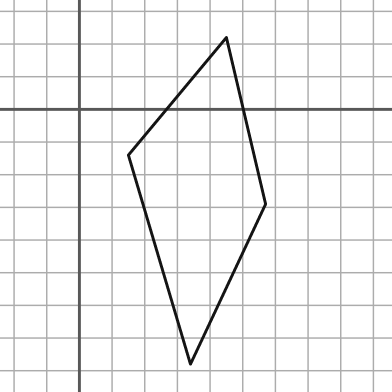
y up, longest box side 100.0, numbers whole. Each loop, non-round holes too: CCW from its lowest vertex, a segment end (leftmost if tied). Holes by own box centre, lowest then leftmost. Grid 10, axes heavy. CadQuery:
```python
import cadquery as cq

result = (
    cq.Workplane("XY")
    .moveTo(34.0, -78.0)
    .lineTo(57.0, -29.0)
    .lineTo(45.0, 22.0)
    .lineTo(15.0, -14.0)
    .close()
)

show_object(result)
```